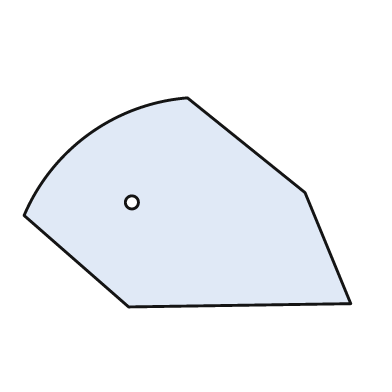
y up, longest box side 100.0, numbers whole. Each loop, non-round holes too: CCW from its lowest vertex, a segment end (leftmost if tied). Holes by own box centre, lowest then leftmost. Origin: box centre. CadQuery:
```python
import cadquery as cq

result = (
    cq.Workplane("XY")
    .moveTo(-18.0, -32.0)
    .lineTo(50.0, -31.0)
    .lineTo(36.0, 3.0)
    .lineTo(0.0, 32.0)
    .threePointArc((-30.0, 21.0), (-50.0, -4.0))
    .close()
    .moveTo(-17.0, 0.0)
    .circle(2.0)
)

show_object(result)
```